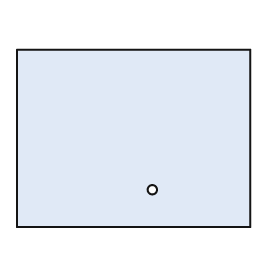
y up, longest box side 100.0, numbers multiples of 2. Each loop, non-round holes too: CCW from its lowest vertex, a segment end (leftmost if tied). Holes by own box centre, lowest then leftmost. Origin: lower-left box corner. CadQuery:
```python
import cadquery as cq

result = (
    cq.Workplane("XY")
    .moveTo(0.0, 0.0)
    .lineTo(100.0, 0.0)
    .lineTo(100.0, 76.0)
    .lineTo(0.0, 76.0)
    .close()
    .moveTo(58.0, 16.0)
    .circle(2.0)
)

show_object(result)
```